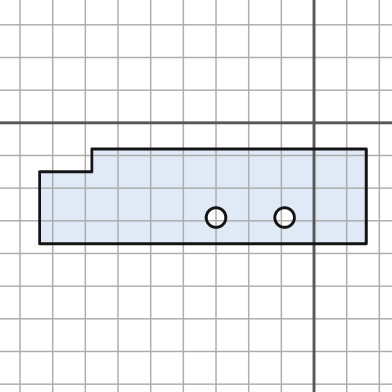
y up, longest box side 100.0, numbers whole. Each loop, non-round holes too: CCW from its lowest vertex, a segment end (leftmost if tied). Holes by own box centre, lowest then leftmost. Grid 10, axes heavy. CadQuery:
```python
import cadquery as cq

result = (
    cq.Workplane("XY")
    .moveTo(-84.0, -37.0)
    .lineTo(16.0, -37.0)
    .lineTo(16.0, -8.0)
    .lineTo(-68.0, -8.0)
    .lineTo(-68.0, -15.0)
    .lineTo(-84.0, -15.0)
    .close()
    .moveTo(-30.0, -29.0)
    .circle(3.0)
    .moveTo(-9.0, -29.0)
    .circle(3.0)
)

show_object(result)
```